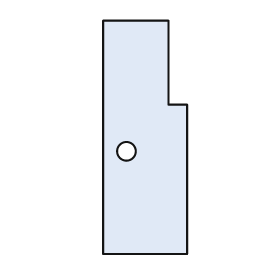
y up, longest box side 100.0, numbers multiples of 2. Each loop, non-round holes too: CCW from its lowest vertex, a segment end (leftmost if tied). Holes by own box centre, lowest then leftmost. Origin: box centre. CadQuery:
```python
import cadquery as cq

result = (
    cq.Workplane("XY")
    .moveTo(-18.0, -50.0)
    .lineTo(18.0, -50.0)
    .lineTo(18.0, 14.0)
    .lineTo(10.0, 14.0)
    .lineTo(10.0, 50.0)
    .lineTo(-18.0, 50.0)
    .close()
    .moveTo(-8.0, -6.0)
    .circle(4.0)
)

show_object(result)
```